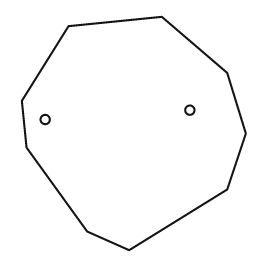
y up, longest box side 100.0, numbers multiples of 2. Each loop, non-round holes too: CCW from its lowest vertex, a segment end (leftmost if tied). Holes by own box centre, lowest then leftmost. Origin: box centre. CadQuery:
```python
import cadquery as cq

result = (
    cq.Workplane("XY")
    .moveTo(-2.0, -50.0)
    .lineTo(40.0, -24.0)
    .lineTo(48.0, 0.0)
    .lineTo(40.0, 26.0)
    .lineTo(12.0, 50.0)
    .lineTo(-28.0, 46.0)
    .lineTo(-48.0, 14.0)
    .lineTo(-46.0, -6.0)
    .lineTo(-20.0, -42.0)
    .close()
    .moveTo(-38.0, 6.0)
    .circle(2.0)
    .moveTo(24.0, 10.0)
    .circle(2.0)
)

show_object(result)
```